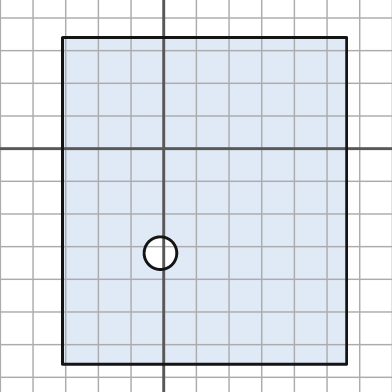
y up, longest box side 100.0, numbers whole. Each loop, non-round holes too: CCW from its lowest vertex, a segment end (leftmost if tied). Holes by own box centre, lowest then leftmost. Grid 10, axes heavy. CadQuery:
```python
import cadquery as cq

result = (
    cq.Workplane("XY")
    .moveTo(-31.0, -66.0)
    .lineTo(56.0, -66.0)
    .lineTo(56.0, 34.0)
    .lineTo(-31.0, 34.0)
    .close()
    .moveTo(-1.0, -32.0)
    .circle(5.0)
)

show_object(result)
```